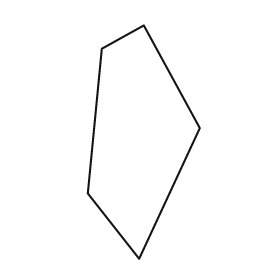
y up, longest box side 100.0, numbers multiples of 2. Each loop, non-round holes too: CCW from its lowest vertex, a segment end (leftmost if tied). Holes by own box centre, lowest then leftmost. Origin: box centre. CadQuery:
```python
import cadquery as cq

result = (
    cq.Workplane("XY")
    .moveTo(-2.0, -50.0)
    .lineTo(24.0, 6.0)
    .lineTo(0.0, 50.0)
    .lineTo(-18.0, 40.0)
    .lineTo(-24.0, -22.0)
    .close()
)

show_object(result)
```